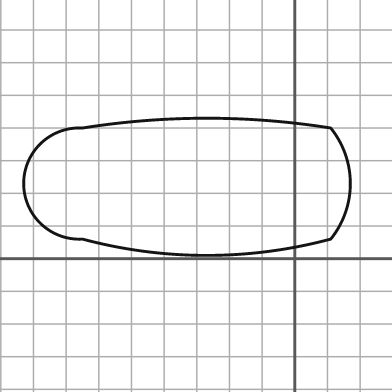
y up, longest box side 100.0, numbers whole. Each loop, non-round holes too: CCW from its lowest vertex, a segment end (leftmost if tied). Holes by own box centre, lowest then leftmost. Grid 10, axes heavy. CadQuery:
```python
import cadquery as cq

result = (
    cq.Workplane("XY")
    .moveTo(-65.0, 6.0)
    .threePointArc((-27.0, 1.0), (11.0, 6.0))
    .threePointArc((17.0, 23.0), (11.0, 40.0))
    .threePointArc((-27.0, 43.0), (-65.0, 40.0))
    .threePointArc((-83.0, 23.0), (-65.0, 6.0))
    .close()
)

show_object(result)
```